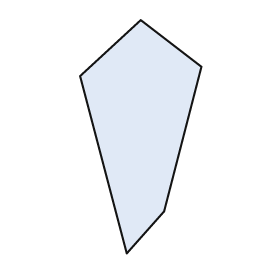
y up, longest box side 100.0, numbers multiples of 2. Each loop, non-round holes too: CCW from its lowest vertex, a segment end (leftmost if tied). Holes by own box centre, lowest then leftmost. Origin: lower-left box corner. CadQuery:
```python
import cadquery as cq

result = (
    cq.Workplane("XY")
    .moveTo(20.0, 0.0)
    .lineTo(36.0, 18.0)
    .lineTo(52.0, 80.0)
    .lineTo(26.0, 100.0)
    .lineTo(0.0, 76.0)
    .close()
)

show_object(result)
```